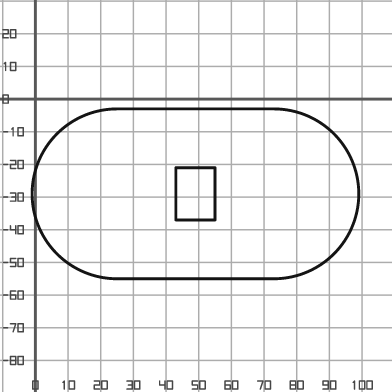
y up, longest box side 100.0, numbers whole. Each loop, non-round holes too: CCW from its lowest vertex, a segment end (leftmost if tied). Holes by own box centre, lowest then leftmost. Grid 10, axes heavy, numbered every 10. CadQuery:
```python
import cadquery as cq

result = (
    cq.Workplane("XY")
    .moveTo(25.0, -55.0)
    .lineTo(73.0, -55.0)
    .threePointArc((99.0, -29.0), (73.0, -3.0))
    .lineTo(25.0, -3.0)
    .threePointArc((-1.0, -29.0), (25.0, -55.0))
    .close()
    .moveTo(43.0, -37.0)
    .lineTo(55.0, -37.0)
    .lineTo(55.0, -21.0)
    .lineTo(43.0, -21.0)
    .close()
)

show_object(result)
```